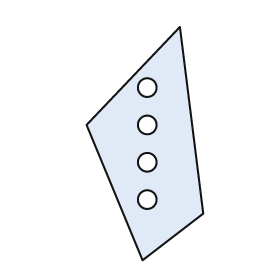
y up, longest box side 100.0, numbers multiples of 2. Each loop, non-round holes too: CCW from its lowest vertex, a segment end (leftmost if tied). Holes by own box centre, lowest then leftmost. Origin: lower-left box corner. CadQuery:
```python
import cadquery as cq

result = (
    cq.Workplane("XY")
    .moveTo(24.0, 0.0)
    .lineTo(50.0, 20.0)
    .lineTo(40.0, 100.0)
    .lineTo(0.0, 58.0)
    .close()
    .moveTo(26.0, 26.0)
    .circle(4.0)
    .moveTo(26.0, 42.0)
    .circle(4.0)
    .moveTo(26.0, 58.0)
    .circle(4.0)
    .moveTo(26.0, 74.0)
    .circle(4.0)
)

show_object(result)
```